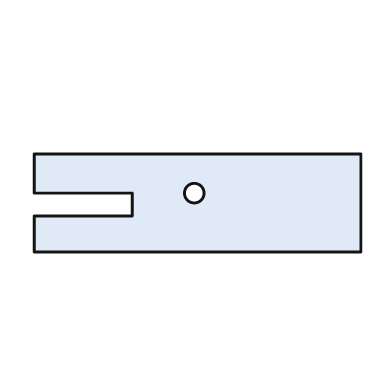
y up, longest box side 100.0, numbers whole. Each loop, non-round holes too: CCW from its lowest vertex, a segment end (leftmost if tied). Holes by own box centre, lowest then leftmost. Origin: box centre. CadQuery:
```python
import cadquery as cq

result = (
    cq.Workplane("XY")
    .moveTo(-50.0, -15.0)
    .lineTo(50.0, -15.0)
    .lineTo(50.0, 15.0)
    .lineTo(-50.0, 15.0)
    .lineTo(-50.0, 3.0)
    .lineTo(-20.0, 3.0)
    .lineTo(-20.0, -4.0)
    .lineTo(-50.0, -4.0)
    .close()
    .moveTo(-1.0, 3.0)
    .circle(3.0)
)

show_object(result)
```